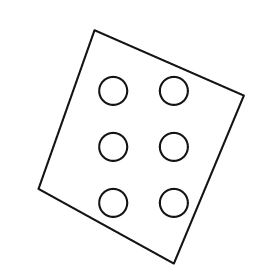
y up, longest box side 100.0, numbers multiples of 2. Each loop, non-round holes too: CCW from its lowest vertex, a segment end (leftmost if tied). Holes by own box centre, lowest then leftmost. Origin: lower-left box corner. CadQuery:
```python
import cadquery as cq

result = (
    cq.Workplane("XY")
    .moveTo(58.0, 0.0)
    .lineTo(88.0, 72.0)
    .lineTo(24.0, 100.0)
    .lineTo(0.0, 32.0)
    .close()
    .moveTo(32.0, 26.0)
    .circle(6.0)
    .moveTo(58.0, 26.0)
    .circle(6.0)
    .moveTo(32.0, 50.0)
    .circle(6.0)
    .moveTo(58.0, 50.0)
    .circle(6.0)
    .moveTo(32.0, 74.0)
    .circle(6.0)
    .moveTo(58.0, 74.0)
    .circle(6.0)
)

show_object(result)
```